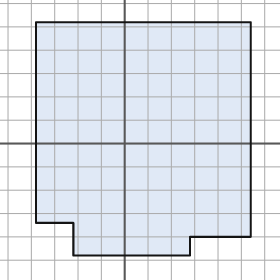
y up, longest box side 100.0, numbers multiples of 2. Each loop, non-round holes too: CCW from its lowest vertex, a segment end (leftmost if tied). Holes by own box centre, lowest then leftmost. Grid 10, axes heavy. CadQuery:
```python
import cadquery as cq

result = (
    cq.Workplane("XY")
    .moveTo(-22.0, -48.0)
    .lineTo(28.0, -48.0)
    .lineTo(28.0, -40.0)
    .lineTo(54.0, -40.0)
    .lineTo(54.0, 52.0)
    .lineTo(-38.0, 52.0)
    .lineTo(-38.0, -34.0)
    .lineTo(-22.0, -34.0)
    .close()
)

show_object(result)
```